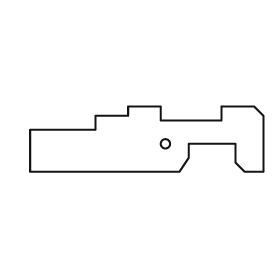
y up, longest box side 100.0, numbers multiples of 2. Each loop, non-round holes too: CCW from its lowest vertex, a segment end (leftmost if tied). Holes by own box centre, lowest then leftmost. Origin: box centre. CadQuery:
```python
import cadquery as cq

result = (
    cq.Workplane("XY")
    .moveTo(-50.0, -14.0)
    .lineTo(14.0, -14.0)
    .lineTo(18.0, -8.0)
    .lineTo(18.0, -2.0)
    .lineTo(38.0, -2.0)
    .lineTo(38.0, -10.0)
    .lineTo(42.0, -14.0)
    .lineTo(50.0, -14.0)
    .lineTo(50.0, 10.0)
    .lineTo(46.0, 14.0)
    .lineTo(32.0, 14.0)
    .lineTo(32.0, 8.0)
    .lineTo(6.0, 8.0)
    .lineTo(6.0, 14.0)
    .lineTo(-8.0, 14.0)
    .lineTo(-8.0, 10.0)
    .lineTo(-22.0, 10.0)
    .lineTo(-22.0, 4.0)
    .lineTo(-50.0, 4.0)
    .close()
    .moveTo(8.0, -2.0)
    .circle(2.0)
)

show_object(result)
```